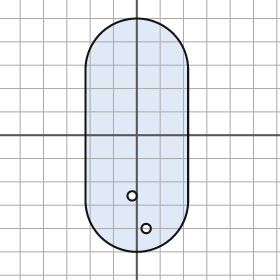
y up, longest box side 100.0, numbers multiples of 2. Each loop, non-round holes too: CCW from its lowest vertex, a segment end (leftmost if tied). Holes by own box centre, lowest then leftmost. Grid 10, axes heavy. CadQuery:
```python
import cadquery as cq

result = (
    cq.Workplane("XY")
    .moveTo(-22.0, -28.0)
    .threePointArc((0.0, -50.0), (22.0, -28.0))
    .lineTo(22.0, 28.0)
    .threePointArc((0.0, 50.0), (-22.0, 28.0))
    .close()
    .moveTo(4.0, -40.0)
    .circle(2.0)
    .moveTo(-2.0, -26.0)
    .circle(2.0)
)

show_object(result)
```